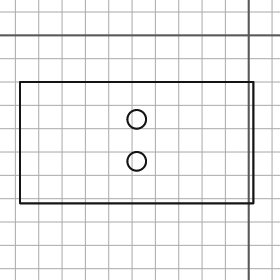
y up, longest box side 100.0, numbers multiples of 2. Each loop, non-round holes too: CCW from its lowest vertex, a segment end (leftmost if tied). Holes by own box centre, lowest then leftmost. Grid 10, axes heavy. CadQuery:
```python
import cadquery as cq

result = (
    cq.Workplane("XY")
    .moveTo(-98.0, -72.0)
    .lineTo(2.0, -72.0)
    .lineTo(2.0, -20.0)
    .lineTo(-98.0, -20.0)
    .close()
    .moveTo(-48.0, -54.0)
    .circle(4.0)
    .moveTo(-48.0, -36.0)
    .circle(4.0)
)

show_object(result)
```